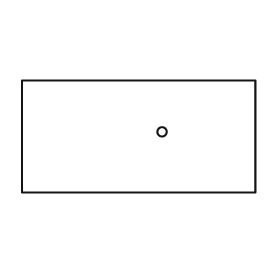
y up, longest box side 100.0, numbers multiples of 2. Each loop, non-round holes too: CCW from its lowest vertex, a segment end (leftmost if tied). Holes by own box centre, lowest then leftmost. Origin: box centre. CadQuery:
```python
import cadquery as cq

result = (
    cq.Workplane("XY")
    .moveTo(-50.0, -24.0)
    .lineTo(50.0, -24.0)
    .lineTo(50.0, 24.0)
    .lineTo(-50.0, 24.0)
    .close()
    .moveTo(10.0, 2.0)
    .circle(2.0)
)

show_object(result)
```